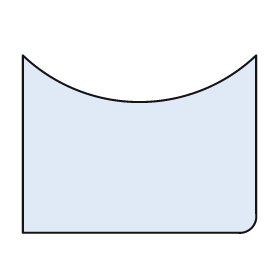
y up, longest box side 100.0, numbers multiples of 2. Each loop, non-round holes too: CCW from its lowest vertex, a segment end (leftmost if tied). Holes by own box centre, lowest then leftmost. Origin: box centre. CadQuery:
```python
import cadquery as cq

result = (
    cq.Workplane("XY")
    .moveTo(-50.0, -38.0)
    .lineTo(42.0, -38.0)
    .threePointArc((48.0, -36.0), (50.0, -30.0))
    .lineTo(50.0, 38.0)
    .threePointArc((0.0, 18.0), (-50.0, 38.0))
    .close()
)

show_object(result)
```